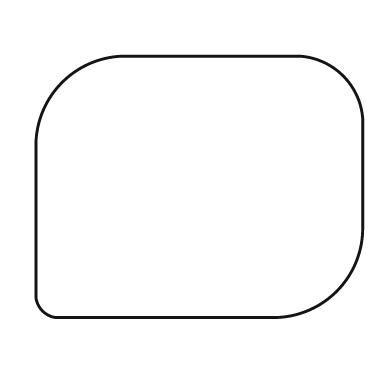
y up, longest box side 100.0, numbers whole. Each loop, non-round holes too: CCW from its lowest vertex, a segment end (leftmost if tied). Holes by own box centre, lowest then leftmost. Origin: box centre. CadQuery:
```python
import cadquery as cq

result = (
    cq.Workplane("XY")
    .moveTo(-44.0, -40.0)
    .lineTo(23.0, -40.0)
    .threePointArc((42.0, -32.0), (50.0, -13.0))
    .lineTo(50.0, 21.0)
    .threePointArc((44.0, 34.0), (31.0, 40.0))
    .lineTo(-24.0, 40.0)
    .threePointArc((-42.0, 32.0), (-50.0, 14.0))
    .lineTo(-50.0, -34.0)
    .threePointArc((-48.0, -38.0), (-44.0, -40.0))
    .close()
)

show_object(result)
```